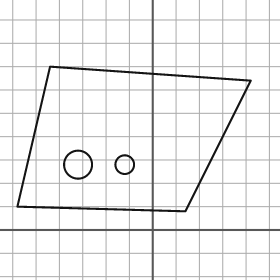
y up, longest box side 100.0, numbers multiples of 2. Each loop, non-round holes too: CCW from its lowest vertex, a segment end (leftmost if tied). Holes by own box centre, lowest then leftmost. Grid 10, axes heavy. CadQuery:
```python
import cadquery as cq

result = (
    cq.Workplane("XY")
    .moveTo(14.0, 8.0)
    .lineTo(42.0, 64.0)
    .lineTo(-44.0, 70.0)
    .lineTo(-58.0, 10.0)
    .close()
    .moveTo(-32.0, 28.0)
    .circle(6.0)
    .moveTo(-12.0, 28.0)
    .circle(4.0)
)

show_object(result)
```